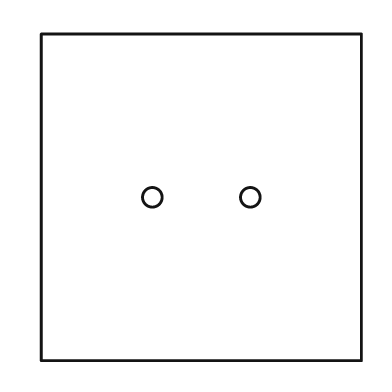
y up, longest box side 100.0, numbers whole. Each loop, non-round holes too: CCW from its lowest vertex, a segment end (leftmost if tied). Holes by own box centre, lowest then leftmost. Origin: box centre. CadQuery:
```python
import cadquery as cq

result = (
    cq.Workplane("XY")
    .moveTo(-49.0, -50.0)
    .lineTo(49.0, -50.0)
    .lineTo(49.0, 50.0)
    .lineTo(-49.0, 50.0)
    .close()
    .moveTo(-15.0, 0.0)
    .circle(3.0)
    .moveTo(15.0, 0.0)
    .circle(3.0)
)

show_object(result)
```